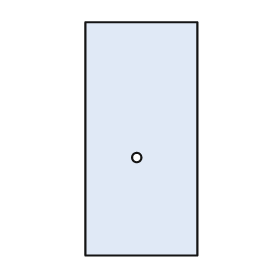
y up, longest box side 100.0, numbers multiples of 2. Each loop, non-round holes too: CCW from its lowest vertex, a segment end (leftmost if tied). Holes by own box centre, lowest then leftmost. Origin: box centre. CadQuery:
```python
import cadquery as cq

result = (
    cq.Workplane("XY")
    .moveTo(-24.0, -50.0)
    .lineTo(24.0, -50.0)
    .lineTo(24.0, 50.0)
    .lineTo(-24.0, 50.0)
    .close()
    .moveTo(-2.0, -8.0)
    .circle(2.0)
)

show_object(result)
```